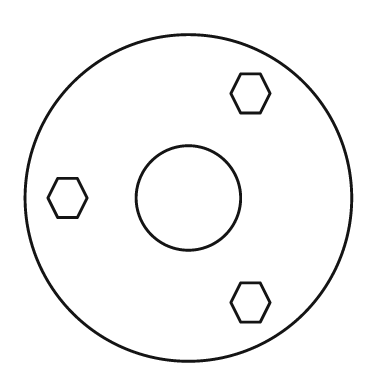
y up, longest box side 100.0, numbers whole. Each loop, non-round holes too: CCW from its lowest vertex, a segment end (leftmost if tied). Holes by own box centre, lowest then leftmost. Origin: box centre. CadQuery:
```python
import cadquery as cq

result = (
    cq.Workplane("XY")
    .moveTo(0.0, 0.0)
    .circle(50.0)
    .moveTo(16.0, -38.0)
    .lineTo(22.0, -38.0)
    .lineTo(25.0, -32.0)
    .lineTo(22.0, -26.0)
    .lineTo(16.0, -26.0)
    .lineTo(13.0, -32.0)
    .close()
    .moveTo(-40.0, -6.0)
    .lineTo(-34.0, -6.0)
    .lineTo(-31.0, 0.0)
    .lineTo(-34.0, 6.0)
    .lineTo(-40.0, 6.0)
    .lineTo(-43.0, 0.0)
    .close()
    .moveTo(0.0, 0.0)
    .circle(16.0)
    .moveTo(16.0, 26.0)
    .lineTo(22.0, 26.0)
    .lineTo(25.0, 32.0)
    .lineTo(22.0, 38.0)
    .lineTo(16.0, 38.0)
    .lineTo(13.0, 32.0)
    .close()
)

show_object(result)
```